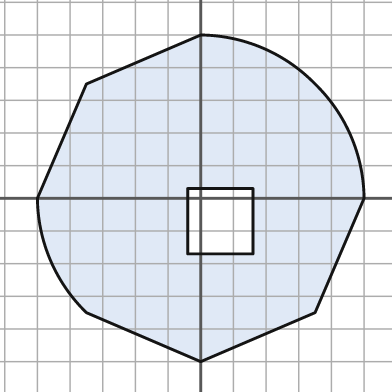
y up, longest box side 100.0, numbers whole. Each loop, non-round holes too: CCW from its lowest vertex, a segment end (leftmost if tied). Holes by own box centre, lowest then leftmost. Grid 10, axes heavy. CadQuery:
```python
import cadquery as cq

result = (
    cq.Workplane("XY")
    .moveTo(0.0, -50.0)
    .lineTo(35.0, -35.0)
    .lineTo(50.0, 0.0)
    .threePointArc((46.0, 19.0), (35.0, 35.0))
    .threePointArc((19.0, 46.0), (0.0, 50.0))
    .lineTo(-35.0, 35.0)
    .lineTo(-50.0, 0.0)
    .threePointArc((-46.0, -19.0), (-35.0, -35.0))
    .close()
    .moveTo(-4.0, -17.0)
    .lineTo(16.0, -17.0)
    .lineTo(16.0, 3.0)
    .lineTo(-4.0, 3.0)
    .close()
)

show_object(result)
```